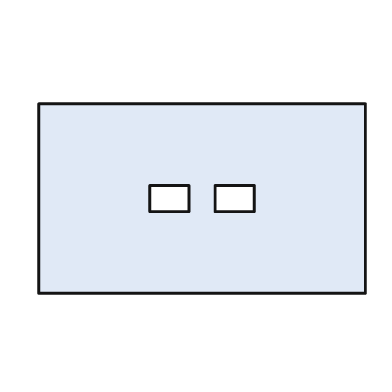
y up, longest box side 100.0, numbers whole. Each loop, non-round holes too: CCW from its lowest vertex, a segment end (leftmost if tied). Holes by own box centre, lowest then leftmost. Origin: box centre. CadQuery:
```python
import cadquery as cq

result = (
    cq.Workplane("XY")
    .moveTo(-50.0, -29.0)
    .lineTo(50.0, -29.0)
    .lineTo(50.0, 29.0)
    .lineTo(-50.0, 29.0)
    .close()
    .moveTo(-16.0, -4.0)
    .lineTo(-4.0, -4.0)
    .lineTo(-4.0, 4.0)
    .lineTo(-16.0, 4.0)
    .close()
    .moveTo(4.0, -4.0)
    .lineTo(16.0, -4.0)
    .lineTo(16.0, 4.0)
    .lineTo(4.0, 4.0)
    .close()
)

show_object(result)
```